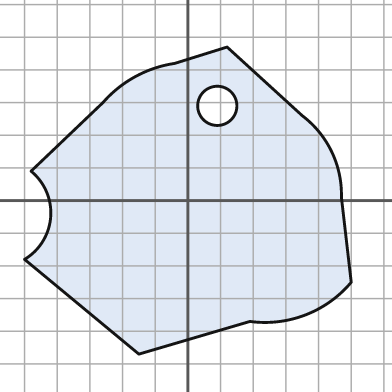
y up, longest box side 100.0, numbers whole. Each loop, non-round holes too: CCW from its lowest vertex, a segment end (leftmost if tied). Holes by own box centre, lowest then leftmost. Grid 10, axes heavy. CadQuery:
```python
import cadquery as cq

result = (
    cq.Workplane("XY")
    .moveTo(-15.0, -47.0)
    .lineTo(19.0, -37.0)
    .threePointArc((36.0, -35.0), (50.0, -25.0))
    .lineTo(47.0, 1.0)
    .threePointArc((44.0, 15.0), (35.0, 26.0))
    .lineTo(12.0, 47.0)
    .lineTo(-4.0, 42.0)
    .threePointArc((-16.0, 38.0), (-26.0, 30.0))
    .lineTo(-48.0, 9.0)
    .threePointArc((-42.0, -5.0), (-50.0, -18.0))
    .close()
    .moveTo(9.0, 29.0)
    .circle(6.0)
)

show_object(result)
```